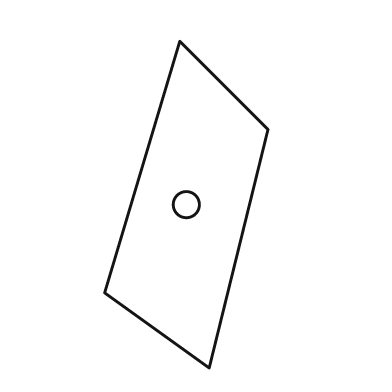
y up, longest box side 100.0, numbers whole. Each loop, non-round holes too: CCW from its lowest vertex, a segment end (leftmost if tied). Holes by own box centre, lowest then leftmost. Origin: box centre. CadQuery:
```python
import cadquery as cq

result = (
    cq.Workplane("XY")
    .moveTo(7.0, -50.0)
    .lineTo(25.0, 23.0)
    .lineTo(-2.0, 50.0)
    .lineTo(-25.0, -27.0)
    .close()
    .moveTo(0.0, 0.0)
    .circle(4.0)
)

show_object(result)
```